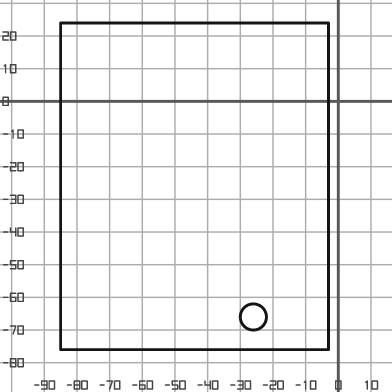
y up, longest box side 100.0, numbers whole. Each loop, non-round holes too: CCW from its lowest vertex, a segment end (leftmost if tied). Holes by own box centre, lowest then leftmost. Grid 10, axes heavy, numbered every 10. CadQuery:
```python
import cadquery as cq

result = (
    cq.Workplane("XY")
    .moveTo(-85.0, -76.0)
    .lineTo(-3.0, -76.0)
    .lineTo(-3.0, 24.0)
    .lineTo(-85.0, 24.0)
    .close()
    .moveTo(-26.0, -66.0)
    .circle(4.0)
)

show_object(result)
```